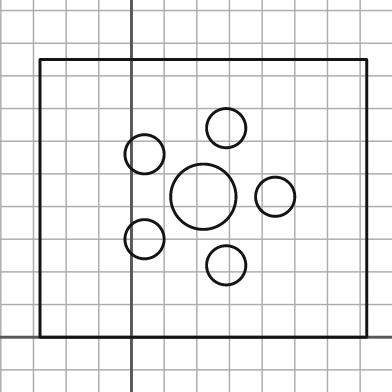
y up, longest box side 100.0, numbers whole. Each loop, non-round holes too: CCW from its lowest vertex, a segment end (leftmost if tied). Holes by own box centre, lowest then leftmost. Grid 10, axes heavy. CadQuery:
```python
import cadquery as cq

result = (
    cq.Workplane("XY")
    .moveTo(-28.0, 0.0)
    .lineTo(72.0, 0.0)
    .lineTo(72.0, 85.0)
    .lineTo(-28.0, 85.0)
    .close()
    .moveTo(29.0, 22.0)
    .circle(6.0)
    .moveTo(4.0, 30.0)
    .circle(6.0)
    .moveTo(22.0, 43.0)
    .circle(10.0)
    .moveTo(44.0, 43.0)
    .circle(6.0)
    .moveTo(4.0, 56.0)
    .circle(6.0)
    .moveTo(29.0, 64.0)
    .circle(6.0)
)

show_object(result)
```